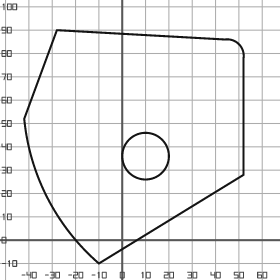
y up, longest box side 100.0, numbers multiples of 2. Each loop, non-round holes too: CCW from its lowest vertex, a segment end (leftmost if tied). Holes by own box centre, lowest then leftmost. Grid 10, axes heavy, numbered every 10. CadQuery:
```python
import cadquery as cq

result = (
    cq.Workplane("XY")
    .moveTo(-10.0, -10.0)
    .lineTo(52.0, 28.0)
    .lineTo(52.0, 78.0)
    .threePointArc((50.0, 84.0), (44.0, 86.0))
    .lineTo(-28.0, 90.0)
    .lineTo(-42.0, 52.0)
    .threePointArc((-32.0, 18.0), (-10.0, -10.0))
    .close()
    .moveTo(10.0, 36.0)
    .circle(10.0)
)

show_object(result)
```